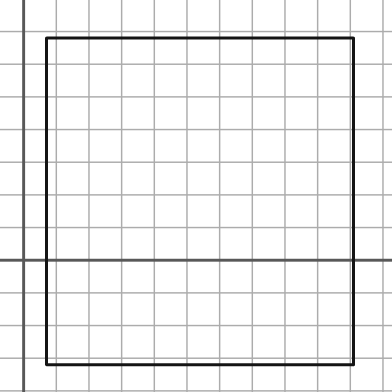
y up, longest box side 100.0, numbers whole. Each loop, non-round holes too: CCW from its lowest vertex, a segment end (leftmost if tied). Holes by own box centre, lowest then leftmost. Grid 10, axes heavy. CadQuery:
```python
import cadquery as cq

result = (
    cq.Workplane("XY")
    .moveTo(7.0, -32.0)
    .lineTo(101.0, -32.0)
    .lineTo(101.0, 68.0)
    .lineTo(7.0, 68.0)
    .close()
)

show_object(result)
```